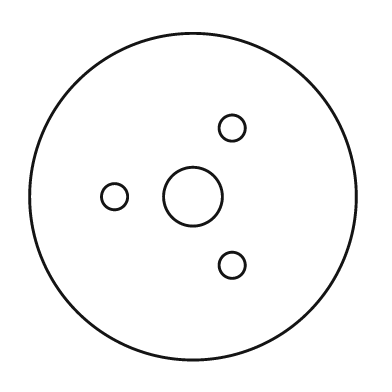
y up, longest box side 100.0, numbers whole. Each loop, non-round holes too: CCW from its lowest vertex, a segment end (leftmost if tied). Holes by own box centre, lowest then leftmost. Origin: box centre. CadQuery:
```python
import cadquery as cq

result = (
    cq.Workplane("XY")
    .moveTo(0.0, 0.0)
    .circle(50.0)
    .moveTo(12.0, -21.0)
    .circle(4.0)
    .moveTo(-24.0, 0.0)
    .circle(4.0)
    .moveTo(0.0, 0.0)
    .circle(9.0)
    .moveTo(12.0, 21.0)
    .circle(4.0)
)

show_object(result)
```